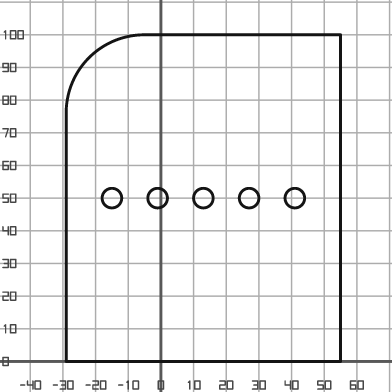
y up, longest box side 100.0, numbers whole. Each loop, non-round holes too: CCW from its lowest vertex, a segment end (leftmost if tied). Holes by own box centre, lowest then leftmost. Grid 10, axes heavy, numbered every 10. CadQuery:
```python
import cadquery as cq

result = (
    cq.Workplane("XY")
    .moveTo(-29.0, 0.0)
    .lineTo(55.0, 0.0)
    .lineTo(55.0, 100.0)
    .lineTo(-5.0, 100.0)
    .threePointArc((-22.0, 93.0), (-29.0, 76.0))
    .close()
    .moveTo(-15.0, 50.0)
    .circle(3.0)
    .moveTo(-1.0, 50.0)
    .circle(3.0)
    .moveTo(13.0, 50.0)
    .circle(3.0)
    .moveTo(27.0, 50.0)
    .circle(3.0)
    .moveTo(41.0, 50.0)
    .circle(3.0)
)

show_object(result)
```